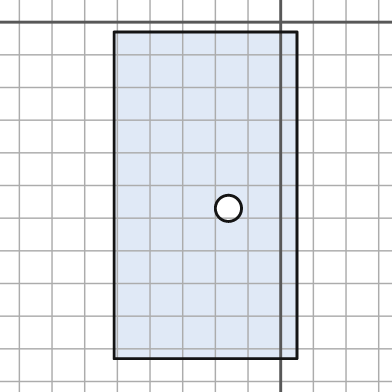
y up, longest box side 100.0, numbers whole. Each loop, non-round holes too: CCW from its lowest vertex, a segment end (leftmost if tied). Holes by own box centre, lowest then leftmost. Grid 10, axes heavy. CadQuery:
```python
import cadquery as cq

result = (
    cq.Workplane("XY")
    .moveTo(-51.0, -103.0)
    .lineTo(5.0, -103.0)
    .lineTo(5.0, -3.0)
    .lineTo(-51.0, -3.0)
    .close()
    .moveTo(-16.0, -57.0)
    .circle(4.0)
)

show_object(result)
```